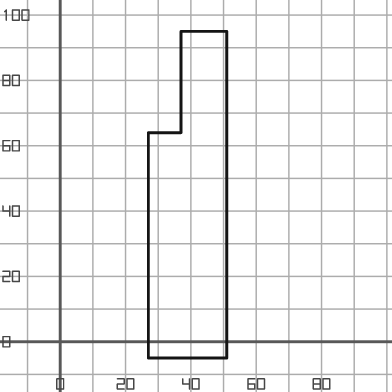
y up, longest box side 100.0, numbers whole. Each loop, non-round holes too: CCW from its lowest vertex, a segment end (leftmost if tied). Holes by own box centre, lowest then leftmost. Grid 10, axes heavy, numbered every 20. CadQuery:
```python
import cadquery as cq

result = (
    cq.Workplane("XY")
    .moveTo(27.0, -5.0)
    .lineTo(51.0, -5.0)
    .lineTo(51.0, 95.0)
    .lineTo(37.0, 95.0)
    .lineTo(37.0, 64.0)
    .lineTo(27.0, 64.0)
    .close()
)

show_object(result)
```